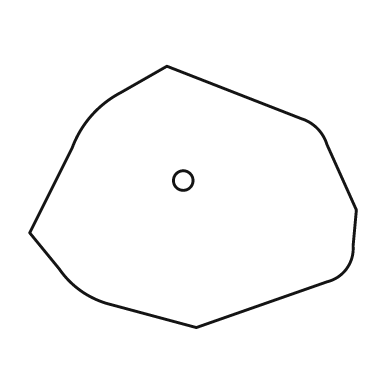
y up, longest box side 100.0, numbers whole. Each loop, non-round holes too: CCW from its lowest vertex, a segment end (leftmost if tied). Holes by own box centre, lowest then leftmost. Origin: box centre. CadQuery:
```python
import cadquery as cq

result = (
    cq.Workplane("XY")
    .moveTo(1.0, -40.0)
    .lineTo(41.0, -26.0)
    .threePointArc((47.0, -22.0), (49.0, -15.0))
    .lineTo(50.0, -4.0)
    .lineTo(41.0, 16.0)
    .threePointArc((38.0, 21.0), (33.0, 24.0))
    .lineTo(-8.0, 40.0)
    .lineTo(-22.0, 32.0)
    .threePointArc((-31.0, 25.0), (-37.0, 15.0))
    .lineTo(-50.0, -11.0)
    .lineTo(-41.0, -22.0)
    .threePointArc((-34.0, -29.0), (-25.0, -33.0))
    .close()
    .moveTo(-3.0, 5.0)
    .circle(3.0)
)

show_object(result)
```